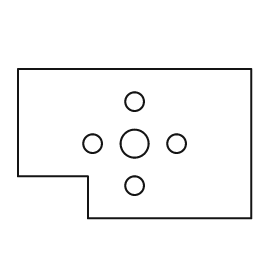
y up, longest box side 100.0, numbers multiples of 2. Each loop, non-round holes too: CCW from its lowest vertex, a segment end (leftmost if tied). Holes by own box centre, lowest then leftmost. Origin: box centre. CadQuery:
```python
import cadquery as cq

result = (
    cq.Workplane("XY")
    .moveTo(-20.0, -32.0)
    .lineTo(50.0, -32.0)
    .lineTo(50.0, 32.0)
    .lineTo(-50.0, 32.0)
    .lineTo(-50.0, -14.0)
    .lineTo(-20.0, -14.0)
    .close()
    .moveTo(0.0, -18.0)
    .circle(4.0)
    .moveTo(-18.0, 0.0)
    .circle(4.0)
    .moveTo(0.0, 0.0)
    .circle(6.0)
    .moveTo(18.0, 0.0)
    .circle(4.0)
    .moveTo(0.0, 18.0)
    .circle(4.0)
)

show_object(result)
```